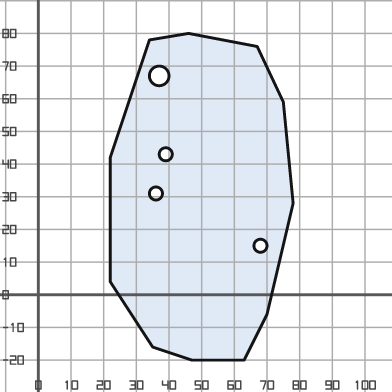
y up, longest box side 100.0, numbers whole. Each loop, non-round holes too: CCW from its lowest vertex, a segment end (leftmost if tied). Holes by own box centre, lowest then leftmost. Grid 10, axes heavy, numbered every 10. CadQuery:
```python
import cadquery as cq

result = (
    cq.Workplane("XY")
    .moveTo(47.0, -20.0)
    .lineTo(63.0, -20.0)
    .lineTo(70.0, -6.0)
    .lineTo(78.0, 28.0)
    .lineTo(75.0, 59.0)
    .lineTo(67.0, 76.0)
    .lineTo(46.0, 80.0)
    .lineTo(34.0, 78.0)
    .lineTo(22.0, 42.0)
    .lineTo(22.0, 4.0)
    .lineTo(35.0, -16.0)
    .close()
    .moveTo(68.0, 15.0)
    .circle(2.0)
    .moveTo(36.0, 31.0)
    .circle(2.0)
    .moveTo(39.0, 43.0)
    .circle(2.0)
    .moveTo(37.0, 67.0)
    .circle(3.0)
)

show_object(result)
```